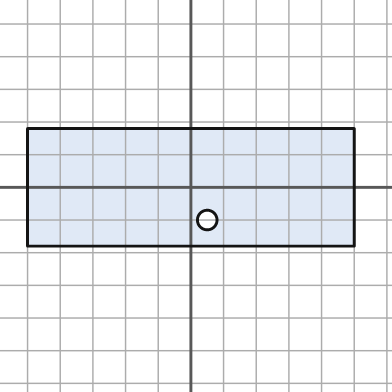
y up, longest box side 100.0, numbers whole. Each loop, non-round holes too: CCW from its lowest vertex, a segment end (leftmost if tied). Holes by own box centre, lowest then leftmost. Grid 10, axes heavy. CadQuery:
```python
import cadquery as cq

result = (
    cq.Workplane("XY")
    .moveTo(-50.0, -18.0)
    .lineTo(50.0, -18.0)
    .lineTo(50.0, 18.0)
    .lineTo(-50.0, 18.0)
    .close()
    .moveTo(5.0, -10.0)
    .circle(3.0)
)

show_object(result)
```